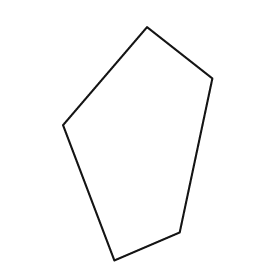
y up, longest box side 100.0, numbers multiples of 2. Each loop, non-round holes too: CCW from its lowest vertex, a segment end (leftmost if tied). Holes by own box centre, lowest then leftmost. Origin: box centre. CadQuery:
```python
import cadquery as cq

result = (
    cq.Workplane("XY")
    .moveTo(-10.0, -50.0)
    .lineTo(18.0, -38.0)
    .lineTo(32.0, 28.0)
    .lineTo(4.0, 50.0)
    .lineTo(-32.0, 8.0)
    .close()
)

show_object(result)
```